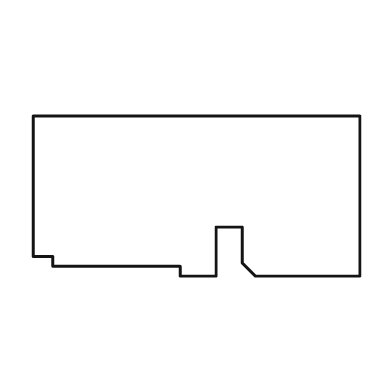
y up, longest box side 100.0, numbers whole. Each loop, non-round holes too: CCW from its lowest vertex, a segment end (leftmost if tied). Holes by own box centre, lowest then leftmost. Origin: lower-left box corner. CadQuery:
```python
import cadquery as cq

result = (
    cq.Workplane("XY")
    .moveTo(45.0, 0.0)
    .lineTo(56.0, 0.0)
    .lineTo(56.0, 15.0)
    .lineTo(64.0, 15.0)
    .lineTo(64.0, 4.0)
    .lineTo(68.0, 0.0)
    .lineTo(100.0, 0.0)
    .lineTo(100.0, 49.0)
    .lineTo(0.0, 49.0)
    .lineTo(0.0, 6.0)
    .lineTo(6.0, 6.0)
    .lineTo(6.0, 3.0)
    .lineTo(45.0, 3.0)
    .close()
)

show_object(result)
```